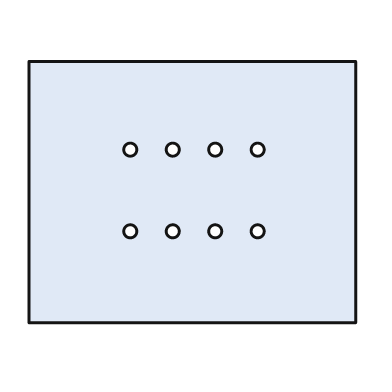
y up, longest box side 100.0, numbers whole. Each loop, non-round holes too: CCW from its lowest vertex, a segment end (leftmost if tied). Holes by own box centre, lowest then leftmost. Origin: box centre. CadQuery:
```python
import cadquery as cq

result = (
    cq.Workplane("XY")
    .moveTo(-50.0, -40.0)
    .lineTo(50.0, -40.0)
    .lineTo(50.0, 40.0)
    .lineTo(-50.0, 40.0)
    .close()
    .moveTo(-19.0, -12.0)
    .circle(2.0)
    .moveTo(-6.0, -12.0)
    .circle(2.0)
    .moveTo(7.0, -12.0)
    .circle(2.0)
    .moveTo(20.0, -12.0)
    .circle(2.0)
    .moveTo(-19.0, 13.0)
    .circle(2.0)
    .moveTo(-6.0, 13.0)
    .circle(2.0)
    .moveTo(7.0, 13.0)
    .circle(2.0)
    .moveTo(20.0, 13.0)
    .circle(2.0)
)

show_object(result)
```